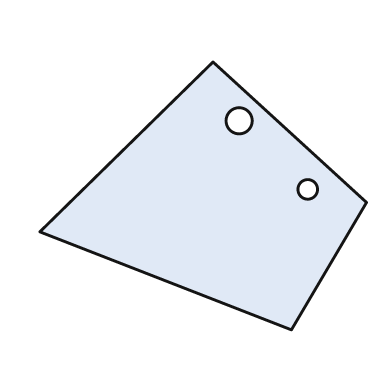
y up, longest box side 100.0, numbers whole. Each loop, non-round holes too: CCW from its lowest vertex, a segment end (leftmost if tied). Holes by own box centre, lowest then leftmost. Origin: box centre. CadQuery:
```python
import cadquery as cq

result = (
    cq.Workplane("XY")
    .moveTo(27.0, -41.0)
    .lineTo(50.0, -2.0)
    .lineTo(3.0, 41.0)
    .lineTo(-50.0, -11.0)
    .close()
    .moveTo(32.0, 2.0)
    .circle(3.0)
    .moveTo(11.0, 23.0)
    .circle(4.0)
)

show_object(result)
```